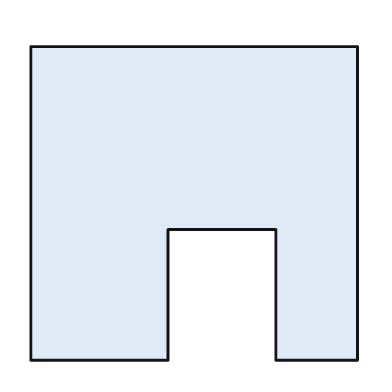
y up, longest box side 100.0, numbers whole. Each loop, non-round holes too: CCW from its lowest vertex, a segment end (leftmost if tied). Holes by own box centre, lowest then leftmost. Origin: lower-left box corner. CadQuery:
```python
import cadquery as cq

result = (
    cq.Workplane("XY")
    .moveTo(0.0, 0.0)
    .lineTo(42.0, 0.0)
    .lineTo(42.0, 40.0)
    .lineTo(75.0, 40.0)
    .lineTo(75.0, 0.0)
    .lineTo(100.0, 0.0)
    .lineTo(100.0, 96.0)
    .lineTo(0.0, 96.0)
    .close()
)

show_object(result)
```